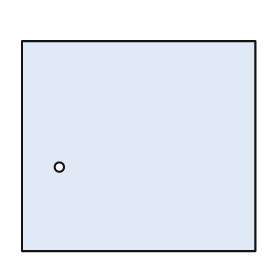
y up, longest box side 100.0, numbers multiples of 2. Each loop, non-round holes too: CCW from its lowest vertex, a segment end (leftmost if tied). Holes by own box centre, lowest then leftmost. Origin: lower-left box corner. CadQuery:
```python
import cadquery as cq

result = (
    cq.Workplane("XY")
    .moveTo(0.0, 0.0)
    .lineTo(100.0, 0.0)
    .lineTo(100.0, 90.0)
    .lineTo(0.0, 90.0)
    .close()
    .moveTo(16.0, 36.0)
    .circle(2.0)
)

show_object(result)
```